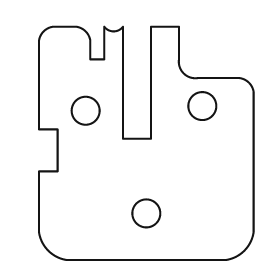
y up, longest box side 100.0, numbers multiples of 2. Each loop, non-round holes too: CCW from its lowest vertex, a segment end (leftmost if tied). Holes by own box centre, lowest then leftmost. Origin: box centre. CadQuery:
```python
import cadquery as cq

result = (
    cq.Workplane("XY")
    .moveTo(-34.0, -50.0)
    .lineTo(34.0, -50.0)
    .threePointArc((42.0, -46.0), (46.0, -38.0))
    .lineTo(46.0, 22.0)
    .threePointArc((44.0, 26.0), (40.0, 28.0))
    .lineTo(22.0, 28.0)
    .threePointArc((16.0, 30.0), (14.0, 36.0))
    .lineTo(14.0, 50.0)
    .lineTo(2.0, 50.0)
    .lineTo(2.0, 2.0)
    .lineTo(-10.0, 2.0)
    .lineTo(-10.0, 50.0)
    .threePointArc((-14.0, 48.0), (-18.0, 50.0))
    .lineTo(-18.0, 36.0)
    .lineTo(-24.0, 36.0)
    .lineTo(-24.0, 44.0)
    .threePointArc((-26.0, 48.0), (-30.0, 50.0))
    .lineTo(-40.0, 50.0)
    .threePointArc((-44.0, 48.0), (-46.0, 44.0))
    .lineTo(-46.0, 6.0)
    .lineTo(-38.0, 6.0)
    .lineTo(-38.0, -12.0)
    .lineTo(-46.0, -12.0)
    .lineTo(-46.0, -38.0)
    .threePointArc((-42.0, -46.0), (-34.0, -50.0))
    .close()
    .moveTo(0.0, -30.0)
    .circle(6.0)
    .moveTo(-26.0, 14.0)
    .circle(6.0)
    .moveTo(24.0, 16.0)
    .circle(6.0)
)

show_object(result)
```